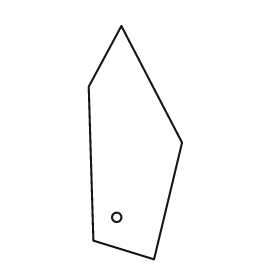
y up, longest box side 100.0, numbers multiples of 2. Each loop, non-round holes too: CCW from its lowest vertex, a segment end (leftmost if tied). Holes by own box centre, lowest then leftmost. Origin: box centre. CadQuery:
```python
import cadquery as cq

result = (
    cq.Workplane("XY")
    .moveTo(8.0, -50.0)
    .lineTo(20.0, 0.0)
    .lineTo(-6.0, 50.0)
    .lineTo(-20.0, 24.0)
    .lineTo(-18.0, -42.0)
    .close()
    .moveTo(-8.0, -32.0)
    .circle(2.0)
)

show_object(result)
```